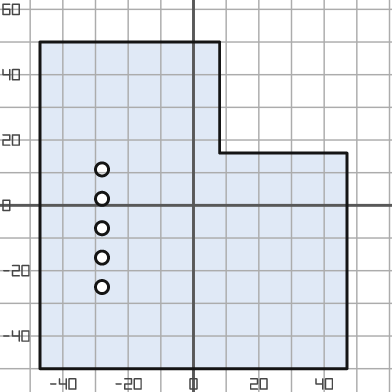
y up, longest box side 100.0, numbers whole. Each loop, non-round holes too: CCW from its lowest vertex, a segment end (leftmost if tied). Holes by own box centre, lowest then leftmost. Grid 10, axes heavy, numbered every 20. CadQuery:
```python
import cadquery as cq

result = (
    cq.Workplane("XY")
    .moveTo(-47.0, -50.0)
    .lineTo(47.0, -50.0)
    .lineTo(47.0, 16.0)
    .lineTo(8.0, 16.0)
    .lineTo(8.0, 50.0)
    .lineTo(-47.0, 50.0)
    .close()
    .moveTo(-28.0, -25.0)
    .circle(2.0)
    .moveTo(-28.0, -16.0)
    .circle(2.0)
    .moveTo(-28.0, -7.0)
    .circle(2.0)
    .moveTo(-28.0, 2.0)
    .circle(2.0)
    .moveTo(-28.0, 11.0)
    .circle(2.0)
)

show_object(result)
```